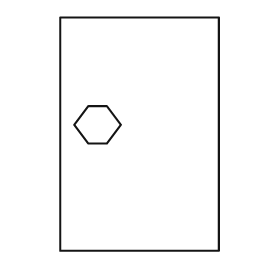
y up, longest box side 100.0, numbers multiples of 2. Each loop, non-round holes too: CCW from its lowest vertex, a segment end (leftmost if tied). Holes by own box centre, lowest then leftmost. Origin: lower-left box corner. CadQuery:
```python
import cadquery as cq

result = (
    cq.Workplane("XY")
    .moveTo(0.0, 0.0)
    .lineTo(68.0, 0.0)
    .lineTo(68.0, 100.0)
    .lineTo(0.0, 100.0)
    .close()
    .moveTo(12.0, 46.0)
    .lineTo(20.0, 46.0)
    .lineTo(26.0, 54.0)
    .lineTo(20.0, 62.0)
    .lineTo(12.0, 62.0)
    .lineTo(6.0, 54.0)
    .close()
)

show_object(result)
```